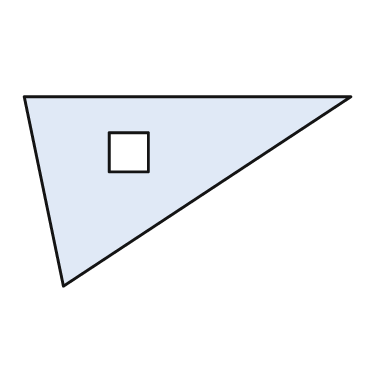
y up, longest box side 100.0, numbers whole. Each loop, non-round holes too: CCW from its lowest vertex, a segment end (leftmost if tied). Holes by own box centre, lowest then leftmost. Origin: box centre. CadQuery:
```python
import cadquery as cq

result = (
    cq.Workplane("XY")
    .moveTo(-38.0, -29.0)
    .lineTo(50.0, 29.0)
    .lineTo(-50.0, 29.0)
    .close()
    .moveTo(-24.0, 6.0)
    .lineTo(-12.0, 6.0)
    .lineTo(-12.0, 18.0)
    .lineTo(-24.0, 18.0)
    .close()
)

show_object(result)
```